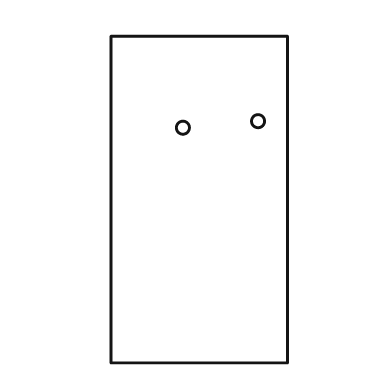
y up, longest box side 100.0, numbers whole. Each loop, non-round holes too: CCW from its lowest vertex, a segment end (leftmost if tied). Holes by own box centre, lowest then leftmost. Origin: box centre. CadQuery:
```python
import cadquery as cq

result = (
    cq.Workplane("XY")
    .moveTo(-27.0, -50.0)
    .lineTo(27.0, -50.0)
    .lineTo(27.0, 50.0)
    .lineTo(-27.0, 50.0)
    .close()
    .moveTo(-5.0, 22.0)
    .circle(2.0)
    .moveTo(18.0, 24.0)
    .circle(2.0)
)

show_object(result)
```